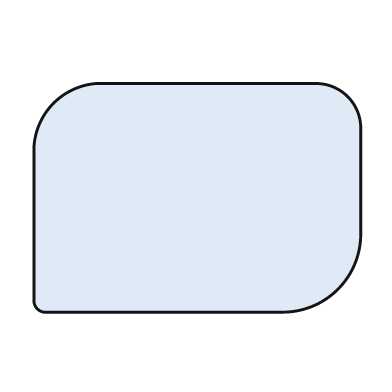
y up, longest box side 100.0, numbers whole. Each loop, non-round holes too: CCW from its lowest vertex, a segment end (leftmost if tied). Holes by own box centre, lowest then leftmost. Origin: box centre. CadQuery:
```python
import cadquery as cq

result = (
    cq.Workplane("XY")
    .moveTo(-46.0, -35.0)
    .lineTo(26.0, -35.0)
    .threePointArc((43.0, -28.0), (50.0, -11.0))
    .lineTo(50.0, 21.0)
    .threePointArc((46.0, 31.0), (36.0, 35.0))
    .lineTo(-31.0, 35.0)
    .threePointArc((-44.0, 29.0), (-50.0, 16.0))
    .lineTo(-50.0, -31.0)
    .threePointArc((-49.0, -34.0), (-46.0, -35.0))
    .close()
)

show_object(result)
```